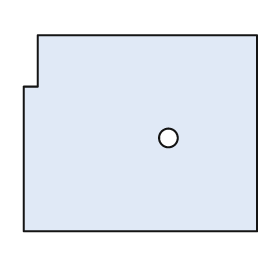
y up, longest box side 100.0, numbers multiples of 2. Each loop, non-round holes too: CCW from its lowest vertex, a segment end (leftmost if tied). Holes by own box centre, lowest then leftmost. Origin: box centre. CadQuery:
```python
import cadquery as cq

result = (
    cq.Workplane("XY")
    .moveTo(-50.0, -42.0)
    .lineTo(50.0, -42.0)
    .lineTo(50.0, 42.0)
    .lineTo(-44.0, 42.0)
    .lineTo(-44.0, 20.0)
    .lineTo(-50.0, 20.0)
    .close()
    .moveTo(12.0, -2.0)
    .circle(4.0)
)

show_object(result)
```